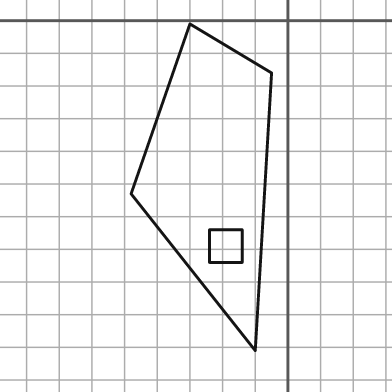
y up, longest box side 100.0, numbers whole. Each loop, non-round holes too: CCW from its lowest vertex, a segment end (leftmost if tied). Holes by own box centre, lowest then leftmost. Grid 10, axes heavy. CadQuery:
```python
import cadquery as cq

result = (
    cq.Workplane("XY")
    .moveTo(-10.0, -101.0)
    .lineTo(-5.0, -16.0)
    .lineTo(-30.0, -1.0)
    .lineTo(-48.0, -53.0)
    .close()
    .moveTo(-24.0, -74.0)
    .lineTo(-14.0, -74.0)
    .lineTo(-14.0, -64.0)
    .lineTo(-24.0, -64.0)
    .close()
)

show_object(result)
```